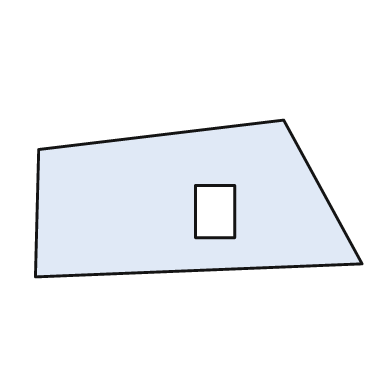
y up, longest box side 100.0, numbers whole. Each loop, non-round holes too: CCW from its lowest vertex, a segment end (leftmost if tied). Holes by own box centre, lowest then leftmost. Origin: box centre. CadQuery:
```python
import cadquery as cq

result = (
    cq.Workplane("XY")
    .moveTo(-50.0, -24.0)
    .lineTo(50.0, -20.0)
    .lineTo(26.0, 24.0)
    .lineTo(-49.0, 15.0)
    .close()
    .moveTo(-1.0, -12.0)
    .lineTo(11.0, -12.0)
    .lineTo(11.0, 4.0)
    .lineTo(-1.0, 4.0)
    .close()
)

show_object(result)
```